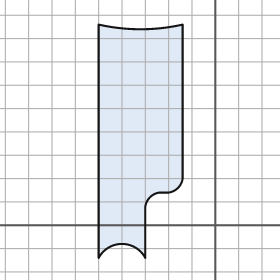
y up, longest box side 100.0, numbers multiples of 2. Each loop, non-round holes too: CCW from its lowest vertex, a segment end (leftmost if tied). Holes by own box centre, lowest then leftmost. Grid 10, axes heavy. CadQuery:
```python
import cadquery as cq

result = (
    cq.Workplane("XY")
    .moveTo(-50.0, -14.0)
    .threePointArc((-40.0, -8.0), (-30.0, -14.0))
    .lineTo(-30.0, 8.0)
    .threePointArc((-28.0, 12.0), (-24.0, 14.0))
    .lineTo(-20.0, 14.0)
    .threePointArc((-16.0, 16.0), (-14.0, 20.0))
    .lineTo(-14.0, 86.0)
    .threePointArc((-32.0, 84.0), (-50.0, 86.0))
    .close()
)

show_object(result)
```